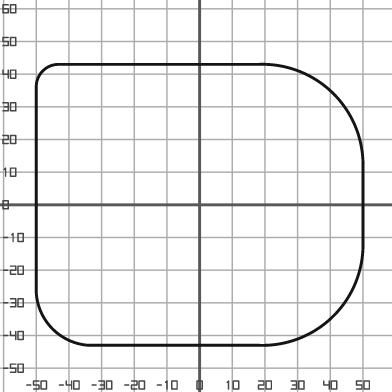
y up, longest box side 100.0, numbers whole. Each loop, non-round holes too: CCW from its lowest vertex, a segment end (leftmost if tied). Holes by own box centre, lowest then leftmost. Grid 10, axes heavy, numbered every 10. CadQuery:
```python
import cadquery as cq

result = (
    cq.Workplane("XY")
    .moveTo(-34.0, -43.0)
    .lineTo(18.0, -43.0)
    .threePointArc((41.0, -34.0), (50.0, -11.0))
    .lineTo(50.0, 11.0)
    .threePointArc((41.0, 34.0), (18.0, 43.0))
    .lineTo(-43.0, 43.0)
    .threePointArc((-48.0, 41.0), (-50.0, 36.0))
    .lineTo(-50.0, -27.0)
    .threePointArc((-45.0, -38.0), (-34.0, -43.0))
    .close()
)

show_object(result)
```